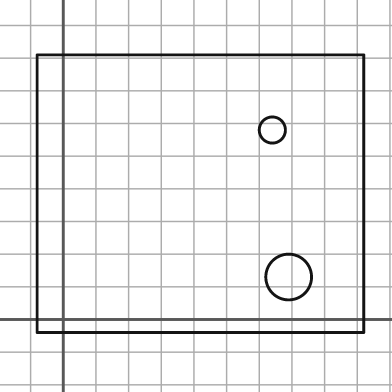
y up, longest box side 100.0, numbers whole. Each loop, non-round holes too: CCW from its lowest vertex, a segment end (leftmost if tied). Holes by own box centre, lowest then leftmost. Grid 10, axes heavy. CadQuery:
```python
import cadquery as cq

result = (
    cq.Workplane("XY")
    .moveTo(-8.0, -4.0)
    .lineTo(92.0, -4.0)
    .lineTo(92.0, 81.0)
    .lineTo(-8.0, 81.0)
    .close()
    .moveTo(69.0, 13.0)
    .circle(7.0)
    .moveTo(64.0, 58.0)
    .circle(4.0)
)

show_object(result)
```